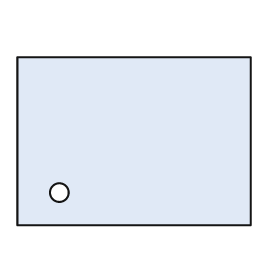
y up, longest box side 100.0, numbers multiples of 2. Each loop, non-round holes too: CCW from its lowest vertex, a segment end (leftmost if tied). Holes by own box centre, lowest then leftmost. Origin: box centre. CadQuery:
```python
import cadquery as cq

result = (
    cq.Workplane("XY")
    .moveTo(-50.0, -36.0)
    .lineTo(50.0, -36.0)
    .lineTo(50.0, 36.0)
    .lineTo(-50.0, 36.0)
    .close()
    .moveTo(-32.0, -22.0)
    .circle(4.0)
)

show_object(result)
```